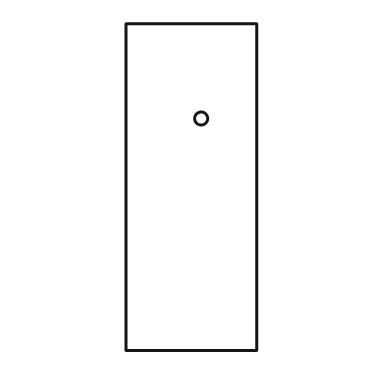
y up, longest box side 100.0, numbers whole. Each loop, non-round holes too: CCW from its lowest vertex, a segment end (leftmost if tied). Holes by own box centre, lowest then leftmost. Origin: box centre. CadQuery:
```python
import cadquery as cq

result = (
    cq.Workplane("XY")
    .moveTo(-20.0, -50.0)
    .lineTo(20.0, -50.0)
    .lineTo(20.0, 50.0)
    .lineTo(-20.0, 50.0)
    .close()
    .moveTo(3.0, 21.0)
    .circle(2.0)
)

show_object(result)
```